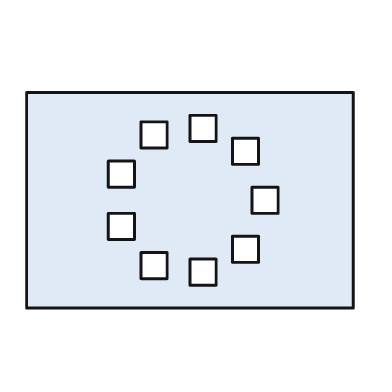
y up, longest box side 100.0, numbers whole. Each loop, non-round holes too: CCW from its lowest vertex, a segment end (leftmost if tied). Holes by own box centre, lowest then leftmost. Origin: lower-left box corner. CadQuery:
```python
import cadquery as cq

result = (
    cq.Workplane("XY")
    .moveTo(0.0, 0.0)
    .lineTo(100.0, 0.0)
    .lineTo(100.0, 66.0)
    .lineTo(0.0, 66.0)
    .close()
    .moveTo(50.0, 7.0)
    .lineTo(58.0, 7.0)
    .lineTo(58.0, 15.0)
    .lineTo(50.0, 15.0)
    .close()
    .moveTo(35.0, 9.0)
    .lineTo(43.0, 9.0)
    .lineTo(43.0, 17.0)
    .lineTo(35.0, 17.0)
    .close()
    .moveTo(63.0, 14.0)
    .lineTo(71.0, 14.0)
    .lineTo(71.0, 22.0)
    .lineTo(63.0, 22.0)
    .close()
    .moveTo(25.0, 21.0)
    .lineTo(33.0, 21.0)
    .lineTo(33.0, 29.0)
    .lineTo(25.0, 29.0)
    .close()
    .moveTo(69.0, 29.0)
    .lineTo(77.0, 29.0)
    .lineTo(77.0, 37.0)
    .lineTo(69.0, 37.0)
    .close()
    .moveTo(25.0, 37.0)
    .lineTo(33.0, 37.0)
    .lineTo(33.0, 45.0)
    .lineTo(25.0, 45.0)
    .close()
    .moveTo(63.0, 44.0)
    .lineTo(71.0, 44.0)
    .lineTo(71.0, 52.0)
    .lineTo(63.0, 52.0)
    .close()
    .moveTo(35.0, 49.0)
    .lineTo(43.0, 49.0)
    .lineTo(43.0, 57.0)
    .lineTo(35.0, 57.0)
    .close()
    .moveTo(50.0, 51.0)
    .lineTo(58.0, 51.0)
    .lineTo(58.0, 59.0)
    .lineTo(50.0, 59.0)
    .close()
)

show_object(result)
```